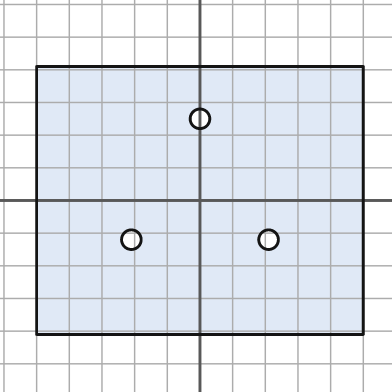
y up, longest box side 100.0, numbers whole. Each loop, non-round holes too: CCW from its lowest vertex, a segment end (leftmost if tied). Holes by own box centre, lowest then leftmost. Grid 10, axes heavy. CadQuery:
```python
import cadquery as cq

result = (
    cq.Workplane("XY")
    .moveTo(-50.0, -41.0)
    .lineTo(50.0, -41.0)
    .lineTo(50.0, 41.0)
    .lineTo(-50.0, 41.0)
    .close()
    .moveTo(-21.0, -12.0)
    .circle(3.0)
    .moveTo(21.0, -12.0)
    .circle(3.0)
    .moveTo(0.0, 25.0)
    .circle(3.0)
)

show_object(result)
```